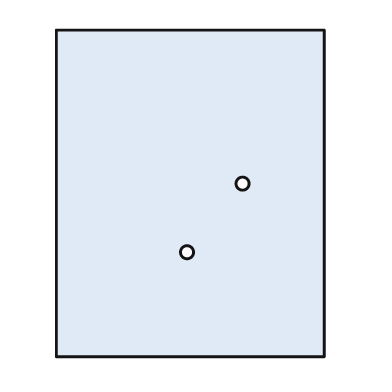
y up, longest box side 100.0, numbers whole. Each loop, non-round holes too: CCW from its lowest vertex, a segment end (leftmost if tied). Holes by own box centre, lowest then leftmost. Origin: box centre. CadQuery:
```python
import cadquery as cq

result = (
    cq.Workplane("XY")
    .moveTo(-41.0, -50.0)
    .lineTo(41.0, -50.0)
    .lineTo(41.0, 50.0)
    .lineTo(-41.0, 50.0)
    .close()
    .moveTo(-1.0, -18.0)
    .circle(2.0)
    .moveTo(16.0, 3.0)
    .circle(2.0)
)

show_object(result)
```